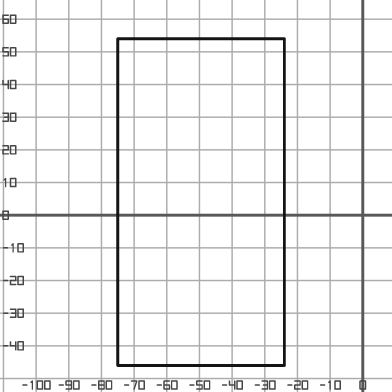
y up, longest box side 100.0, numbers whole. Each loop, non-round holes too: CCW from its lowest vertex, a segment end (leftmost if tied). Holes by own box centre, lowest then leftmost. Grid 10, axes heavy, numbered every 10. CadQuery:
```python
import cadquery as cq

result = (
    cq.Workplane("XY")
    .moveTo(-75.0, -46.0)
    .lineTo(-24.0, -46.0)
    .lineTo(-24.0, 54.0)
    .lineTo(-75.0, 54.0)
    .close()
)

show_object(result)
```